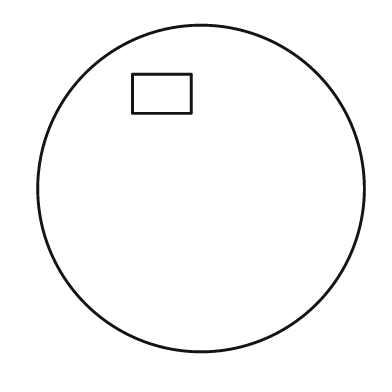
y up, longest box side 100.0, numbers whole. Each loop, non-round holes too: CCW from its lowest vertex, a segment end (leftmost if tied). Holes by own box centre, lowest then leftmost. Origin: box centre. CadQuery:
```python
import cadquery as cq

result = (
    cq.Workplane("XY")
    .moveTo(0.0, 0.0)
    .circle(50.0)
    .moveTo(-21.0, 23.0)
    .lineTo(-3.0, 23.0)
    .lineTo(-3.0, 35.0)
    .lineTo(-21.0, 35.0)
    .close()
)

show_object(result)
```